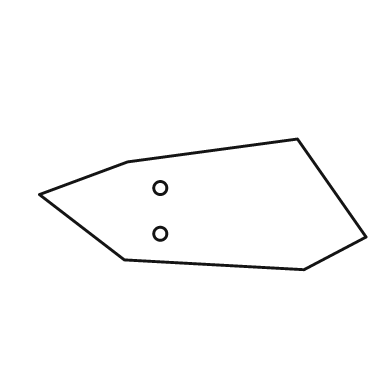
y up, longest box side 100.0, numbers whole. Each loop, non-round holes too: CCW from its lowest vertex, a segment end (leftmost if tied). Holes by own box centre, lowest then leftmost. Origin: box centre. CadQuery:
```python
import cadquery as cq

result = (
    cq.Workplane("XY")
    .moveTo(31.0, -20.0)
    .lineTo(50.0, -10.0)
    .lineTo(29.0, 20.0)
    .lineTo(-23.0, 13.0)
    .lineTo(-50.0, 3.0)
    .lineTo(-24.0, -17.0)
    .close()
    .moveTo(-13.0, -9.0)
    .circle(2.0)
    .moveTo(-13.0, 5.0)
    .circle(2.0)
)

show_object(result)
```